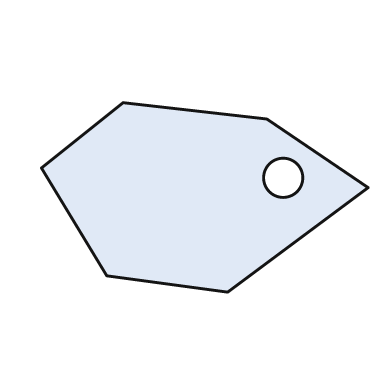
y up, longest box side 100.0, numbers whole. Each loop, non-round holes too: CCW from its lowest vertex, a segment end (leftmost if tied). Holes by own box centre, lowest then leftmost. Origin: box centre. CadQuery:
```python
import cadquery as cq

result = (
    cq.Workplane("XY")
    .moveTo(7.0, -29.0)
    .lineTo(50.0, 3.0)
    .lineTo(19.0, 24.0)
    .lineTo(-25.0, 29.0)
    .lineTo(-50.0, 9.0)
    .lineTo(-30.0, -24.0)
    .close()
    .moveTo(24.0, 6.0)
    .circle(6.0)
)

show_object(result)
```